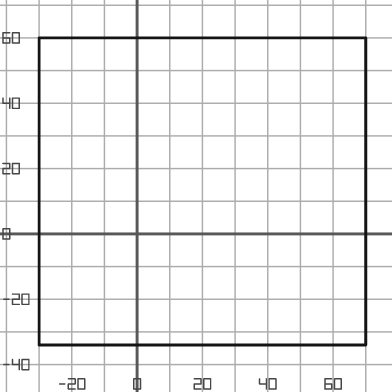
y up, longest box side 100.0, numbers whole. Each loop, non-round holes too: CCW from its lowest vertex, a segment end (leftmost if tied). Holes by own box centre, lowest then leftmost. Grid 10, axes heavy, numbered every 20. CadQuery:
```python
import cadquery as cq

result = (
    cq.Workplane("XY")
    .moveTo(-30.0, -34.0)
    .lineTo(70.0, -34.0)
    .lineTo(70.0, 60.0)
    .lineTo(-30.0, 60.0)
    .close()
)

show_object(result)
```